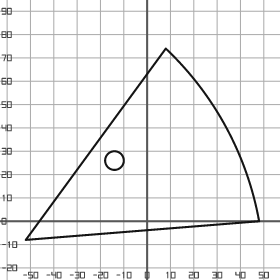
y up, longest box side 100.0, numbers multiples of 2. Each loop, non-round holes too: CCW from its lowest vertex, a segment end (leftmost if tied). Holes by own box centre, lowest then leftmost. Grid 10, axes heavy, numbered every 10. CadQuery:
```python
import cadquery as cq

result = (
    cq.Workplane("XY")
    .moveTo(-52.0, -8.0)
    .lineTo(48.0, 0.0)
    .threePointArc((34.0, 40.0), (8.0, 74.0))
    .close()
    .moveTo(-14.0, 26.0)
    .circle(4.0)
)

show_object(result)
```